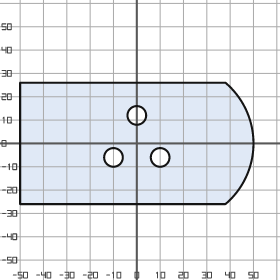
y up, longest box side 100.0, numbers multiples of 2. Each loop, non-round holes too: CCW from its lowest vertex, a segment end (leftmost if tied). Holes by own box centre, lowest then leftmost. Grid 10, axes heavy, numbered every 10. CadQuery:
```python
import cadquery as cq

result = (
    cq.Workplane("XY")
    .moveTo(-50.0, -26.0)
    .lineTo(38.0, -26.0)
    .threePointArc((50.0, 0.0), (38.0, 26.0))
    .lineTo(-50.0, 26.0)
    .close()
    .moveTo(-10.0, -6.0)
    .circle(4.0)
    .moveTo(10.0, -6.0)
    .circle(4.0)
    .moveTo(0.0, 12.0)
    .circle(4.0)
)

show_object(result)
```